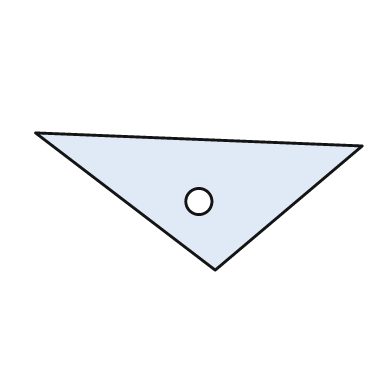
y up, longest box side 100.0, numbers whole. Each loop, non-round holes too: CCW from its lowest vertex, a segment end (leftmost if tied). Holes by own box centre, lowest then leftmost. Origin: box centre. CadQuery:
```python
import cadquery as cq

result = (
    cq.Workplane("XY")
    .moveTo(5.0, -21.0)
    .lineTo(50.0, 17.0)
    .lineTo(-50.0, 21.0)
    .close()
    .moveTo(0.0, 0.0)
    .circle(4.0)
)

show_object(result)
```